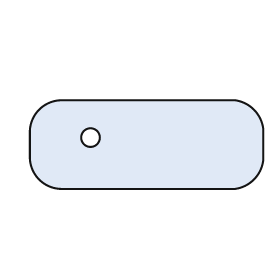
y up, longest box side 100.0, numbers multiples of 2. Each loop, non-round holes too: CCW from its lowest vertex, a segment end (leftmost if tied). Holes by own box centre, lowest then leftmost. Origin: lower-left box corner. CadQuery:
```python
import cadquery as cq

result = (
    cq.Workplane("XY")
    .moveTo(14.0, 0.0)
    .lineTo(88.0, 0.0)
    .threePointArc((96.0, 4.0), (100.0, 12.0))
    .lineTo(100.0, 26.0)
    .threePointArc((96.0, 34.0), (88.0, 38.0))
    .lineTo(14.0, 38.0)
    .threePointArc((4.0, 34.0), (0.0, 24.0))
    .lineTo(0.0, 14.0)
    .threePointArc((4.0, 4.0), (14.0, 0.0))
    .close()
    .moveTo(26.0, 22.0)
    .circle(4.0)
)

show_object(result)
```